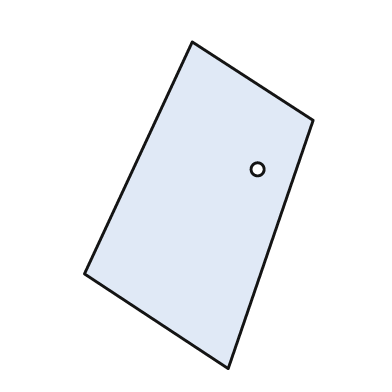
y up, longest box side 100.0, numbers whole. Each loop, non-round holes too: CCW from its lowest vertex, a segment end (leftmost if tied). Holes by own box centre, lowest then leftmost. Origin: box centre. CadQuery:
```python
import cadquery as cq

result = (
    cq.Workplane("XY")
    .moveTo(9.0, -50.0)
    .lineTo(35.0, 26.0)
    .lineTo(-2.0, 50.0)
    .lineTo(-35.0, -21.0)
    .close()
    .moveTo(18.0, 11.0)
    .circle(2.0)
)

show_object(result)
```